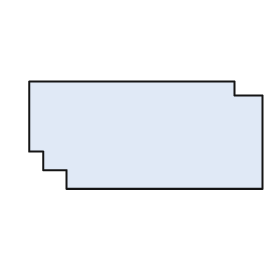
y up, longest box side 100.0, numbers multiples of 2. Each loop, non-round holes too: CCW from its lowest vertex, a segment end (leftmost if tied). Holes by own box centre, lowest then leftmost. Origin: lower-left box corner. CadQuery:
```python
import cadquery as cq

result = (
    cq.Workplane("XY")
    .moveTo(16.0, 0.0)
    .lineTo(100.0, 0.0)
    .lineTo(100.0, 40.0)
    .lineTo(88.0, 40.0)
    .lineTo(88.0, 46.0)
    .lineTo(0.0, 46.0)
    .lineTo(0.0, 16.0)
    .lineTo(6.0, 16.0)
    .lineTo(6.0, 8.0)
    .lineTo(16.0, 8.0)
    .close()
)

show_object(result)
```